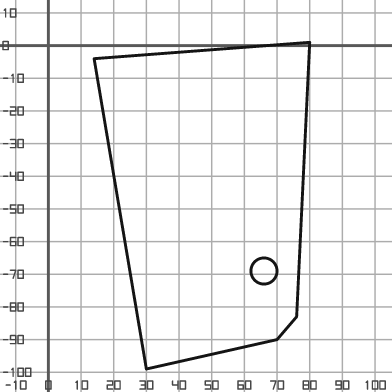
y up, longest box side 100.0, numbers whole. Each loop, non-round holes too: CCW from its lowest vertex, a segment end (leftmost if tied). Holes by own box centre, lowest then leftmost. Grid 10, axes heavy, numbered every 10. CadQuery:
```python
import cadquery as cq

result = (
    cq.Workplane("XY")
    .moveTo(30.0, -99.0)
    .lineTo(70.0, -90.0)
    .lineTo(76.0, -83.0)
    .lineTo(80.0, 1.0)
    .lineTo(14.0, -4.0)
    .close()
    .moveTo(66.0, -69.0)
    .circle(4.0)
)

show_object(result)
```